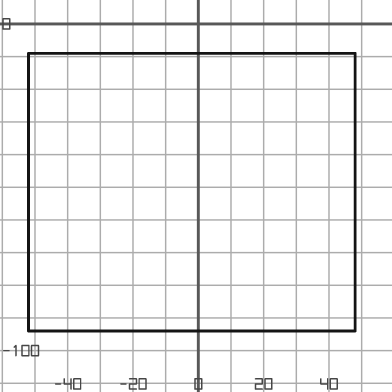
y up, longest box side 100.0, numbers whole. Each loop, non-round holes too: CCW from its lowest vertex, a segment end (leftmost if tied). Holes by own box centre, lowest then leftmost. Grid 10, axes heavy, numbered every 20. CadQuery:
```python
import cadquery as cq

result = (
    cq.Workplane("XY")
    .moveTo(-52.0, -94.0)
    .lineTo(48.0, -94.0)
    .lineTo(48.0, -9.0)
    .lineTo(-52.0, -9.0)
    .close()
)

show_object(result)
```